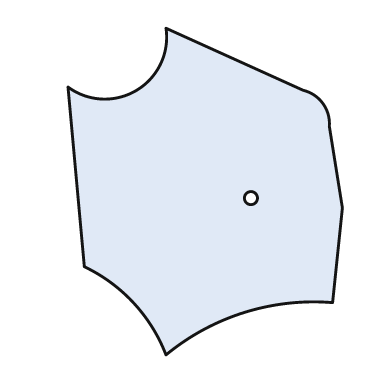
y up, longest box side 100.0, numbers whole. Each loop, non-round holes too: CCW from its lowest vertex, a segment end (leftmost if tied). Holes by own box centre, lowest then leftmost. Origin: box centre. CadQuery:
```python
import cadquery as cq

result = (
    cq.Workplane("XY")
    .moveTo(-12.0, -50.0)
    .threePointArc((12.0, -37.0), (39.0, -34.0))
    .lineTo(42.0, -5.0)
    .lineTo(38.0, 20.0)
    .threePointArc((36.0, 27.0), (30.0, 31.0))
    .lineTo(-12.0, 50.0)
    .threePointArc((-21.0, 31.0), (-42.0, 32.0))
    .lineTo(-37.0, -23.0)
    .threePointArc((-22.0, -34.0), (-12.0, -50.0))
    .close()
    .moveTo(14.0, -2.0)
    .circle(2.0)
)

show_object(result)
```